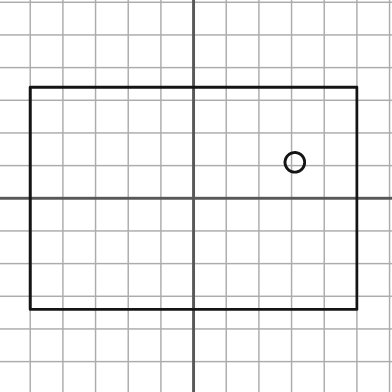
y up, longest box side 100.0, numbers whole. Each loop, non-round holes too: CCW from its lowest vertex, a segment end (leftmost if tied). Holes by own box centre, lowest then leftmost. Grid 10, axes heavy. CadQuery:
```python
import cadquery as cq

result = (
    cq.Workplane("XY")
    .moveTo(-50.0, -34.0)
    .lineTo(50.0, -34.0)
    .lineTo(50.0, 34.0)
    .lineTo(-50.0, 34.0)
    .close()
    .moveTo(31.0, 11.0)
    .circle(3.0)
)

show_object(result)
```